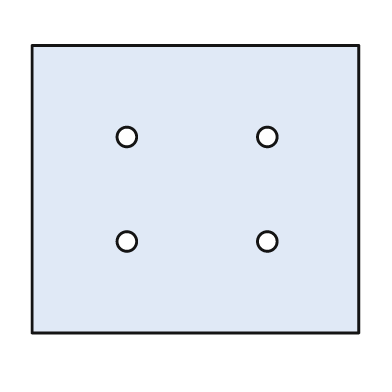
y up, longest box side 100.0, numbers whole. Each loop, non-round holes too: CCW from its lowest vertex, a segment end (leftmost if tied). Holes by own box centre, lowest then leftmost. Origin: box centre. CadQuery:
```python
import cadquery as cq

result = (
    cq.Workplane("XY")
    .moveTo(-50.0, -44.0)
    .lineTo(50.0, -44.0)
    .lineTo(50.0, 44.0)
    .lineTo(-50.0, 44.0)
    .close()
    .moveTo(-21.0, -16.0)
    .circle(3.0)
    .moveTo(22.0, -16.0)
    .circle(3.0)
    .moveTo(-21.0, 16.0)
    .circle(3.0)
    .moveTo(22.0, 16.0)
    .circle(3.0)
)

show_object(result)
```